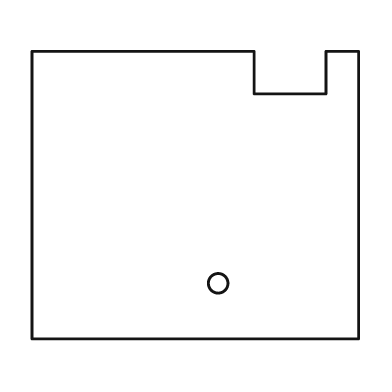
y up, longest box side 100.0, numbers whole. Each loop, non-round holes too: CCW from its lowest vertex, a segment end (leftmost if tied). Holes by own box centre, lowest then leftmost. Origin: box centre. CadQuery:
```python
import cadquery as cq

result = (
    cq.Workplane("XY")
    .moveTo(-50.0, -44.0)
    .lineTo(50.0, -44.0)
    .lineTo(50.0, 44.0)
    .lineTo(40.0, 44.0)
    .lineTo(40.0, 31.0)
    .lineTo(18.0, 31.0)
    .lineTo(18.0, 44.0)
    .lineTo(-50.0, 44.0)
    .close()
    .moveTo(7.0, -27.0)
    .circle(3.0)
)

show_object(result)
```